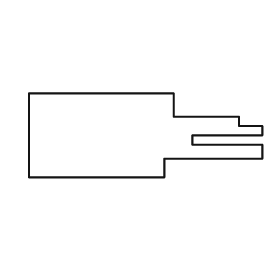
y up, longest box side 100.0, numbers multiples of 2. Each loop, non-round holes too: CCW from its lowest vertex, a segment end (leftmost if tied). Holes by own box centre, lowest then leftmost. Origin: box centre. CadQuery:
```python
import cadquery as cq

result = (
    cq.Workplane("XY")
    .moveTo(-50.0, -18.0)
    .lineTo(8.0, -18.0)
    .lineTo(8.0, -10.0)
    .lineTo(50.0, -10.0)
    .lineTo(50.0, -4.0)
    .lineTo(20.0, -4.0)
    .lineTo(20.0, 0.0)
    .lineTo(50.0, 0.0)
    .lineTo(50.0, 4.0)
    .lineTo(40.0, 4.0)
    .lineTo(40.0, 8.0)
    .lineTo(12.0, 8.0)
    .lineTo(12.0, 18.0)
    .lineTo(-50.0, 18.0)
    .close()
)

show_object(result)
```